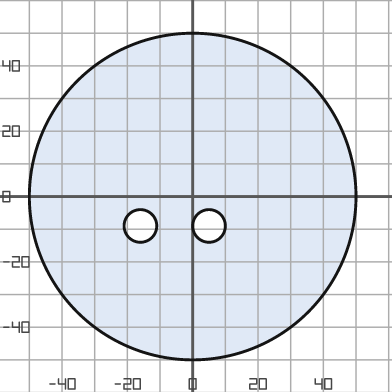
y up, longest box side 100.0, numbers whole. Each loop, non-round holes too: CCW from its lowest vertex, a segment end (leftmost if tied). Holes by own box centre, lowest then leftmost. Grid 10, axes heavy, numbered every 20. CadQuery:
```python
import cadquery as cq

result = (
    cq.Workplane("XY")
    .moveTo(0.0, 0.0)
    .circle(50.0)
    .moveTo(-16.0, -9.0)
    .circle(5.0)
    .moveTo(5.0, -9.0)
    .circle(5.0)
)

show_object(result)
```